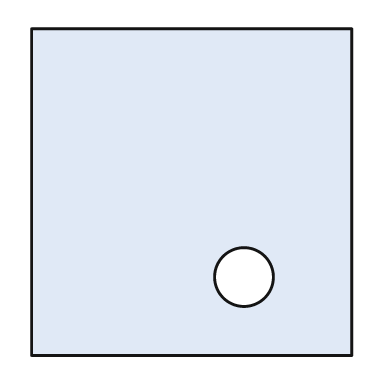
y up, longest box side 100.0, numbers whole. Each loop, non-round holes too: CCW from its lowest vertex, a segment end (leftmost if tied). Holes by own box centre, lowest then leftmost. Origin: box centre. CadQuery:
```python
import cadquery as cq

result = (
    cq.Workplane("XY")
    .moveTo(-49.0, -50.0)
    .lineTo(49.0, -50.0)
    .lineTo(49.0, 50.0)
    .lineTo(-49.0, 50.0)
    .close()
    .moveTo(16.0, -26.0)
    .circle(9.0)
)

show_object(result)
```